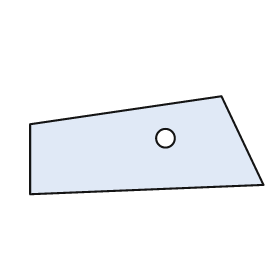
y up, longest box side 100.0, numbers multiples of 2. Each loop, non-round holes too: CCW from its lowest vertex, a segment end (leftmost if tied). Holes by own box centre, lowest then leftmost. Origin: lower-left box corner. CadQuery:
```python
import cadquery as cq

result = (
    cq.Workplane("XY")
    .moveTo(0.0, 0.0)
    .lineTo(100.0, 4.0)
    .lineTo(82.0, 42.0)
    .lineTo(0.0, 30.0)
    .close()
    .moveTo(58.0, 24.0)
    .circle(4.0)
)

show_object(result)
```